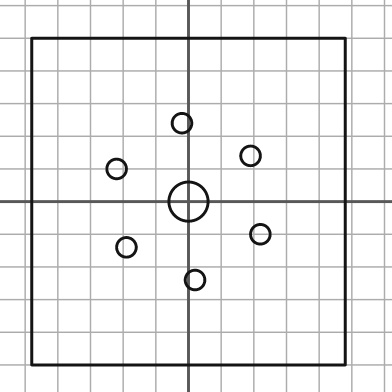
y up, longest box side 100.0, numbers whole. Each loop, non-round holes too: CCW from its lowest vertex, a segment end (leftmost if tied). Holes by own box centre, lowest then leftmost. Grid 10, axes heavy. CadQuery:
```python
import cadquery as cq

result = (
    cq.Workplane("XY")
    .moveTo(-48.0, -50.0)
    .lineTo(48.0, -50.0)
    .lineTo(48.0, 50.0)
    .lineTo(-48.0, 50.0)
    .close()
    .moveTo(2.0, -24.0)
    .circle(3.0)
    .moveTo(-19.0, -14.0)
    .circle(3.0)
    .moveTo(22.0, -10.0)
    .circle(3.0)
    .moveTo(0.0, 0.0)
    .circle(6.0)
    .moveTo(-22.0, 10.0)
    .circle(3.0)
    .moveTo(19.0, 14.0)
    .circle(3.0)
    .moveTo(-2.0, 24.0)
    .circle(3.0)
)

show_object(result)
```